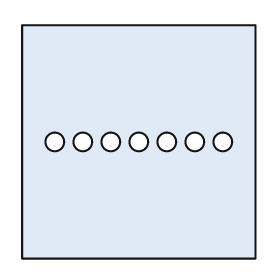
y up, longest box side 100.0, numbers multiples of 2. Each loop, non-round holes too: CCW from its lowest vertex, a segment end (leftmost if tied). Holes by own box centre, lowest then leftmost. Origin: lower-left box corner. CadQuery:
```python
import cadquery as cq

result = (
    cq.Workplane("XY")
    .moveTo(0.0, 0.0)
    .lineTo(100.0, 0.0)
    .lineTo(100.0, 100.0)
    .lineTo(0.0, 100.0)
    .close()
    .moveTo(14.0, 50.0)
    .circle(4.0)
    .moveTo(26.0, 50.0)
    .circle(4.0)
    .moveTo(38.0, 50.0)
    .circle(4.0)
    .moveTo(50.0, 50.0)
    .circle(4.0)
    .moveTo(62.0, 50.0)
    .circle(4.0)
    .moveTo(74.0, 50.0)
    .circle(4.0)
    .moveTo(86.0, 50.0)
    .circle(4.0)
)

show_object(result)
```